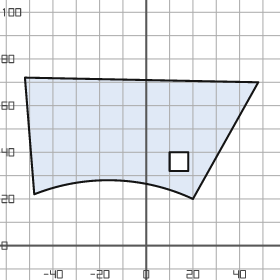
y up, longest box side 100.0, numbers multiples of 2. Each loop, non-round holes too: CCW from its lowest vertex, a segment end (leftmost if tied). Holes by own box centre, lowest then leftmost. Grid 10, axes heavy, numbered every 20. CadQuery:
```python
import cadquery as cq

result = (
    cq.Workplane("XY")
    .moveTo(20.0, 20.0)
    .lineTo(48.0, 70.0)
    .lineTo(-52.0, 72.0)
    .lineTo(-48.0, 22.0)
    .threePointArc((-14.0, 28.0), (20.0, 20.0))
    .close()
    .moveTo(10.0, 32.0)
    .lineTo(18.0, 32.0)
    .lineTo(18.0, 40.0)
    .lineTo(10.0, 40.0)
    .close()
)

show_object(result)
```